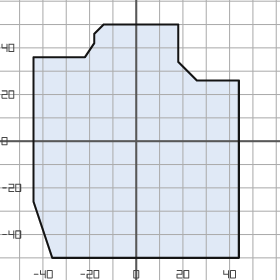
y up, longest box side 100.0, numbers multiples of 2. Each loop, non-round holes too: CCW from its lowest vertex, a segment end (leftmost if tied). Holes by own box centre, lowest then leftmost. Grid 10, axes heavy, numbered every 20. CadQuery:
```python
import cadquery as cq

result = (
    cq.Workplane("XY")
    .moveTo(-36.0, -50.0)
    .lineTo(44.0, -50.0)
    .lineTo(44.0, 26.0)
    .lineTo(26.0, 26.0)
    .lineTo(18.0, 34.0)
    .lineTo(18.0, 50.0)
    .lineTo(-14.0, 50.0)
    .lineTo(-18.0, 46.0)
    .lineTo(-18.0, 42.0)
    .lineTo(-22.0, 36.0)
    .lineTo(-44.0, 36.0)
    .lineTo(-44.0, -26.0)
    .close()
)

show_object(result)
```